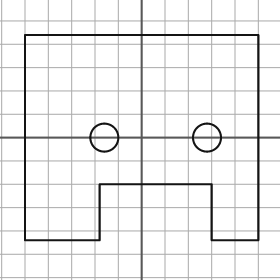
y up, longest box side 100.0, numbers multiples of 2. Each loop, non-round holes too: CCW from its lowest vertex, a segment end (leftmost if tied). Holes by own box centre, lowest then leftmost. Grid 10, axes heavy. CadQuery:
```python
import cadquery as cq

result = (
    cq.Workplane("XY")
    .moveTo(-50.0, -44.0)
    .lineTo(-18.0, -44.0)
    .lineTo(-18.0, -20.0)
    .lineTo(30.0, -20.0)
    .lineTo(30.0, -44.0)
    .lineTo(50.0, -44.0)
    .lineTo(50.0, 44.0)
    .lineTo(-50.0, 44.0)
    .close()
    .moveTo(-16.0, 0.0)
    .circle(6.0)
    .moveTo(28.0, 0.0)
    .circle(6.0)
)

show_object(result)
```